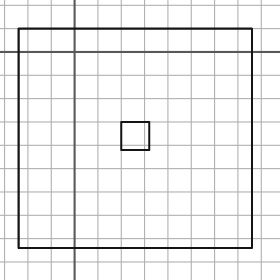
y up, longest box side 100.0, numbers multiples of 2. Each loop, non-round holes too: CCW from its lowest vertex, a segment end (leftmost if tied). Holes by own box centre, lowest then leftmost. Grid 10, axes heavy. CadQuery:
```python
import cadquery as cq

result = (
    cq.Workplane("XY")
    .moveTo(-24.0, -84.0)
    .lineTo(76.0, -84.0)
    .lineTo(76.0, 10.0)
    .lineTo(-24.0, 10.0)
    .close()
    .moveTo(20.0, -42.0)
    .lineTo(32.0, -42.0)
    .lineTo(32.0, -30.0)
    .lineTo(20.0, -30.0)
    .close()
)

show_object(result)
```